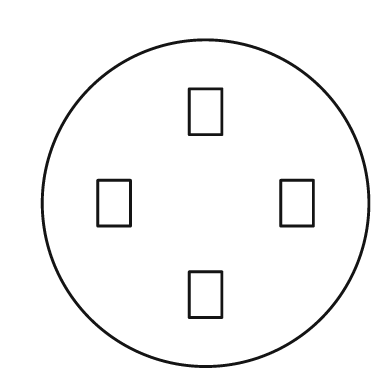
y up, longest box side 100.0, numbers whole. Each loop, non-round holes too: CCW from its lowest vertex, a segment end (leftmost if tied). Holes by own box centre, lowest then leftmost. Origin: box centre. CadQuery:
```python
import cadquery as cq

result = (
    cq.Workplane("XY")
    .moveTo(0.0, 0.0)
    .circle(50.0)
    .moveTo(-5.0, -35.0)
    .lineTo(5.0, -35.0)
    .lineTo(5.0, -21.0)
    .lineTo(-5.0, -21.0)
    .close()
    .moveTo(-33.0, -7.0)
    .lineTo(-23.0, -7.0)
    .lineTo(-23.0, 7.0)
    .lineTo(-33.0, 7.0)
    .close()
    .moveTo(23.0, -7.0)
    .lineTo(33.0, -7.0)
    .lineTo(33.0, 7.0)
    .lineTo(23.0, 7.0)
    .close()
    .moveTo(-5.0, 21.0)
    .lineTo(5.0, 21.0)
    .lineTo(5.0, 35.0)
    .lineTo(-5.0, 35.0)
    .close()
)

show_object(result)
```